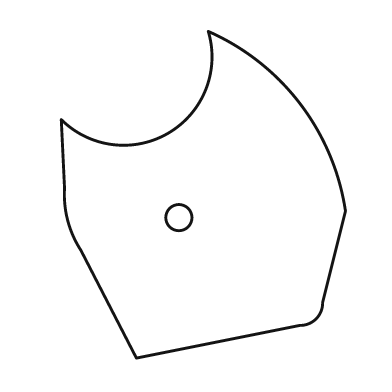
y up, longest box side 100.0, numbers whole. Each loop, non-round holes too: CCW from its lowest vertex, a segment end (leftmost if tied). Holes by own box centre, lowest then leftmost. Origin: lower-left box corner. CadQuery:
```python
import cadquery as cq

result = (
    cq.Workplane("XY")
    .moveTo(23.0, 0.0)
    .lineTo(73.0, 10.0)
    .threePointArc((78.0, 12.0), (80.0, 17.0))
    .lineTo(87.0, 45.0)
    .threePointArc((73.0, 78.0), (45.0, 100.0))
    .threePointArc((33.0, 69.0), (0.0, 73.0))
    .lineTo(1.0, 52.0)
    .threePointArc((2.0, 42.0), (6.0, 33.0))
    .close()
    .moveTo(36.0, 43.0)
    .circle(4.0)
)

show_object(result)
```